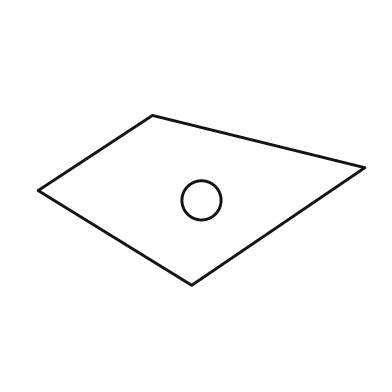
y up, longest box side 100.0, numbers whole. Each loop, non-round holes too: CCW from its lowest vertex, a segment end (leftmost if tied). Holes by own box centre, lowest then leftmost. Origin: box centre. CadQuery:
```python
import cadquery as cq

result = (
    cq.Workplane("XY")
    .moveTo(-3.0, -26.0)
    .lineTo(50.0, 10.0)
    .lineTo(-15.0, 26.0)
    .lineTo(-50.0, 3.0)
    .close()
    .moveTo(0.0, 0.0)
    .circle(6.0)
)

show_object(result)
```